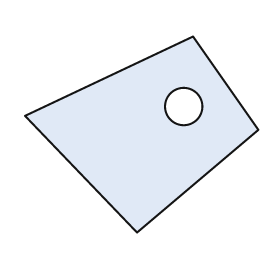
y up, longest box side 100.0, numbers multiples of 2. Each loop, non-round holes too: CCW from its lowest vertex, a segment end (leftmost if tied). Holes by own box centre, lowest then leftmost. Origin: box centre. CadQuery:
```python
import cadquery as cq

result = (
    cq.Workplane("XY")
    .moveTo(-2.0, -42.0)
    .lineTo(50.0, 2.0)
    .lineTo(22.0, 42.0)
    .lineTo(-50.0, 8.0)
    .close()
    .moveTo(18.0, 12.0)
    .circle(8.0)
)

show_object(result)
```